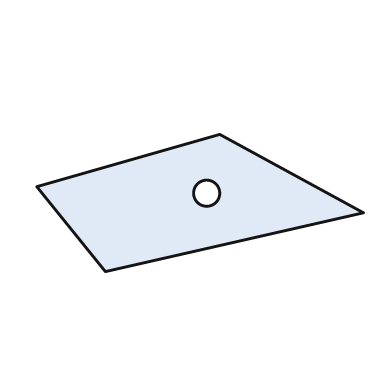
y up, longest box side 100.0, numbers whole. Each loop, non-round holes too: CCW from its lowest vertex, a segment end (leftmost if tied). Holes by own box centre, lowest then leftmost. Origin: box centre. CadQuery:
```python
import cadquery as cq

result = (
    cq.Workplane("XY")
    .moveTo(-29.0, -21.0)
    .lineTo(50.0, -3.0)
    .lineTo(6.0, 21.0)
    .lineTo(-50.0, 5.0)
    .close()
    .moveTo(2.0, 3.0)
    .circle(4.0)
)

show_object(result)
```